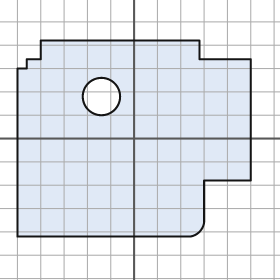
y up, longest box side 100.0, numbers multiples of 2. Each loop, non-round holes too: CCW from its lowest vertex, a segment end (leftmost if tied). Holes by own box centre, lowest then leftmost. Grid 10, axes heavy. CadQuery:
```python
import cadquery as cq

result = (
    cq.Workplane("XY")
    .moveTo(-50.0, -42.0)
    .lineTo(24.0, -42.0)
    .threePointArc((28.0, -40.0), (30.0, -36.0))
    .lineTo(30.0, -18.0)
    .lineTo(50.0, -18.0)
    .lineTo(50.0, 34.0)
    .lineTo(28.0, 34.0)
    .lineTo(28.0, 42.0)
    .lineTo(-40.0, 42.0)
    .lineTo(-40.0, 34.0)
    .lineTo(-46.0, 34.0)
    .lineTo(-46.0, 30.0)
    .lineTo(-50.0, 30.0)
    .close()
    .moveTo(-14.0, 18.0)
    .circle(8.0)
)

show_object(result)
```